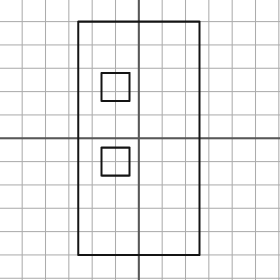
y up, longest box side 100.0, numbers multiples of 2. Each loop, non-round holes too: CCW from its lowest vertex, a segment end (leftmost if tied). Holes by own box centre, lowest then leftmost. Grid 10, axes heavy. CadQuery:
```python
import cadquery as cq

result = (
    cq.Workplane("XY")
    .moveTo(-26.0, -50.0)
    .lineTo(26.0, -50.0)
    .lineTo(26.0, 50.0)
    .lineTo(-26.0, 50.0)
    .close()
    .moveTo(-16.0, -16.0)
    .lineTo(-4.0, -16.0)
    .lineTo(-4.0, -4.0)
    .lineTo(-16.0, -4.0)
    .close()
    .moveTo(-16.0, 16.0)
    .lineTo(-4.0, 16.0)
    .lineTo(-4.0, 28.0)
    .lineTo(-16.0, 28.0)
    .close()
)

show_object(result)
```